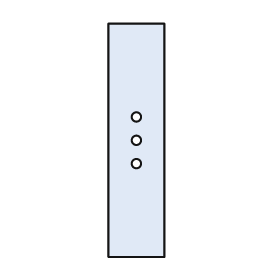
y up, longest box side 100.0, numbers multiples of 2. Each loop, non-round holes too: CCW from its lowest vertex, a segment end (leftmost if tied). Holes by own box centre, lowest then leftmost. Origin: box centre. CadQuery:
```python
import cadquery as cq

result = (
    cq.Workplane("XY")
    .moveTo(-12.0, -50.0)
    .lineTo(12.0, -50.0)
    .lineTo(12.0, 50.0)
    .lineTo(-12.0, 50.0)
    .close()
    .moveTo(0.0, -10.0)
    .circle(2.0)
    .moveTo(0.0, 0.0)
    .circle(2.0)
    .moveTo(0.0, 10.0)
    .circle(2.0)
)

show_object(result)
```